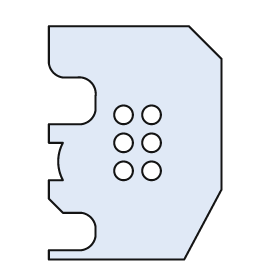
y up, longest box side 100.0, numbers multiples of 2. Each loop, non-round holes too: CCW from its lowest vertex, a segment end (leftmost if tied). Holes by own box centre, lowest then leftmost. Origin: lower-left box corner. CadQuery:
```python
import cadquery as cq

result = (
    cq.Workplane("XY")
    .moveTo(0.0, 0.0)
    .lineTo(58.0, 0.0)
    .lineTo(74.0, 30.0)
    .lineTo(74.0, 86.0)
    .lineTo(60.0, 100.0)
    .lineTo(0.0, 100.0)
    .lineTo(0.0, 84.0)
    .threePointArc((2.0, 80.0), (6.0, 78.0))
    .lineTo(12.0, 78.0)
    .threePointArc((18.0, 76.0), (20.0, 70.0))
    .lineTo(20.0, 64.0)
    .threePointArc((18.0, 60.0), (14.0, 58.0))
    .lineTo(0.0, 58.0)
    .lineTo(0.0, 50.0)
    .lineTo(6.0, 50.0)
    .threePointArc((4.0, 42.0), (6.0, 34.0))
    .lineTo(0.0, 34.0)
    .lineTo(0.0, 26.0)
    .lineTo(6.0, 20.0)
    .lineTo(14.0, 20.0)
    .threePointArc((18.0, 18.0), (20.0, 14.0))
    .lineTo(20.0, 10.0)
    .threePointArc((18.0, 6.0), (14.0, 4.0))
    .lineTo(0.0, 4.0)
    .close()
    .moveTo(32.0, 38.0)
    .circle(4.0)
    .moveTo(44.0, 38.0)
    .circle(4.0)
    .moveTo(32.0, 50.0)
    .circle(4.0)
    .moveTo(44.0, 50.0)
    .circle(4.0)
    .moveTo(32.0, 62.0)
    .circle(4.0)
    .moveTo(44.0, 62.0)
    .circle(4.0)
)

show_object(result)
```